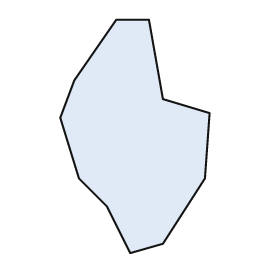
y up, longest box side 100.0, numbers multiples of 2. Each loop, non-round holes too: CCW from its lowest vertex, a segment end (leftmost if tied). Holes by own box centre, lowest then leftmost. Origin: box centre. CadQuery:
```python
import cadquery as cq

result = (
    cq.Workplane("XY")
    .moveTo(-2.0, -50.0)
    .lineTo(12.0, -46.0)
    .lineTo(30.0, -18.0)
    .lineTo(32.0, 10.0)
    .lineTo(12.0, 16.0)
    .lineTo(6.0, 50.0)
    .lineTo(-8.0, 50.0)
    .lineTo(-26.0, 24.0)
    .lineTo(-32.0, 8.0)
    .lineTo(-24.0, -18.0)
    .lineTo(-12.0, -30.0)
    .close()
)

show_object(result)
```